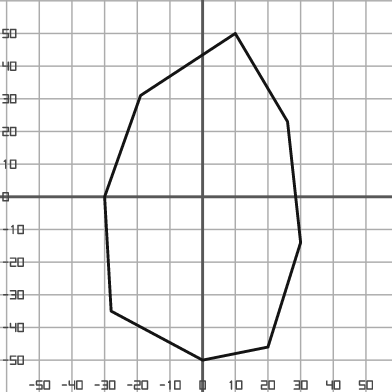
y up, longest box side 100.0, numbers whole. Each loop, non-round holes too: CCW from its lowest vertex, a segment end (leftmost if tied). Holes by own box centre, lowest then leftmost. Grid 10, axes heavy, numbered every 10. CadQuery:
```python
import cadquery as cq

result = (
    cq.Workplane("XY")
    .moveTo(0.0, -50.0)
    .lineTo(20.0, -46.0)
    .lineTo(30.0, -14.0)
    .lineTo(26.0, 23.0)
    .lineTo(10.0, 50.0)
    .lineTo(-19.0, 31.0)
    .lineTo(-30.0, 0.0)
    .lineTo(-28.0, -35.0)
    .close()
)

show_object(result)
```